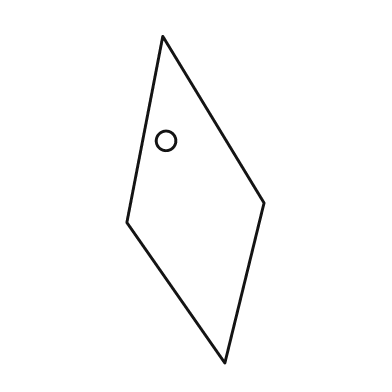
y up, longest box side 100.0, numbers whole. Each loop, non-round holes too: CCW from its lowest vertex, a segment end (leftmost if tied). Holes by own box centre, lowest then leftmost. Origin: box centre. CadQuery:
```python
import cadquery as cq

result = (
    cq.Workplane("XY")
    .moveTo(9.0, -50.0)
    .lineTo(21.0, -1.0)
    .lineTo(-10.0, 50.0)
    .lineTo(-21.0, -7.0)
    .close()
    .moveTo(-9.0, 18.0)
    .circle(3.0)
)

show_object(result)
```